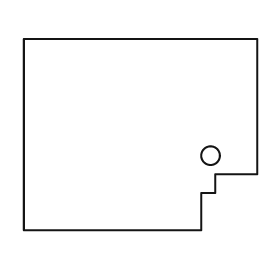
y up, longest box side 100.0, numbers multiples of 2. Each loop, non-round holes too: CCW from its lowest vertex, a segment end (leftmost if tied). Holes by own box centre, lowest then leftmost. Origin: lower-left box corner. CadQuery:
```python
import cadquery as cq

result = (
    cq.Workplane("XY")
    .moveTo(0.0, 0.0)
    .lineTo(76.0, 0.0)
    .lineTo(76.0, 16.0)
    .lineTo(82.0, 16.0)
    .lineTo(82.0, 24.0)
    .lineTo(100.0, 24.0)
    .lineTo(100.0, 82.0)
    .lineTo(0.0, 82.0)
    .close()
    .moveTo(80.0, 32.0)
    .circle(4.0)
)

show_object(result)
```